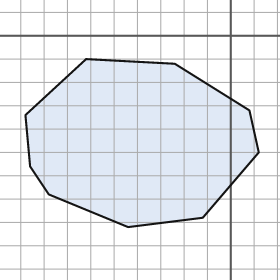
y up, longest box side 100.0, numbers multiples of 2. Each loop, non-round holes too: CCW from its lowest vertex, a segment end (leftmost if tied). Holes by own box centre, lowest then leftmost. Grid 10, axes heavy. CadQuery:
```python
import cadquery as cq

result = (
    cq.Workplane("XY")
    .moveTo(-44.0, -82.0)
    .lineTo(-12.0, -78.0)
    .lineTo(12.0, -50.0)
    .lineTo(8.0, -32.0)
    .lineTo(-24.0, -12.0)
    .lineTo(-62.0, -10.0)
    .lineTo(-88.0, -34.0)
    .lineTo(-86.0, -56.0)
    .lineTo(-78.0, -68.0)
    .close()
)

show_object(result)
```